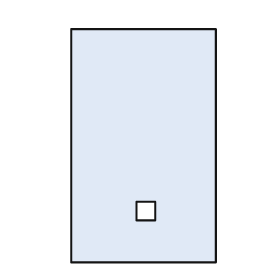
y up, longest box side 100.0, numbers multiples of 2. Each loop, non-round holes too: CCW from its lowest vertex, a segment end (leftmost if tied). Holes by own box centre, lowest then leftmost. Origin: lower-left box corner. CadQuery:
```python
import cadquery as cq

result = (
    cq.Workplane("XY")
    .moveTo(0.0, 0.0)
    .lineTo(62.0, 0.0)
    .lineTo(62.0, 100.0)
    .lineTo(0.0, 100.0)
    .close()
    .moveTo(28.0, 18.0)
    .lineTo(36.0, 18.0)
    .lineTo(36.0, 26.0)
    .lineTo(28.0, 26.0)
    .close()
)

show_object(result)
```